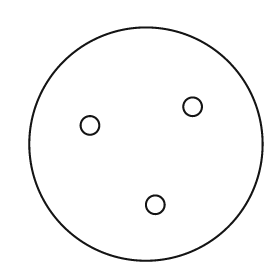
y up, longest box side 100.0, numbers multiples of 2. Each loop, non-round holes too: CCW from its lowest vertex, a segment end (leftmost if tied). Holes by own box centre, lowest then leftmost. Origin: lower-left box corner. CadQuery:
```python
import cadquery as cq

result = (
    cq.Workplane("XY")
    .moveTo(50.0, 50.0)
    .circle(50.0)
    .moveTo(54.0, 24.0)
    .circle(4.0)
    .moveTo(26.0, 58.0)
    .circle(4.0)
    .moveTo(70.0, 66.0)
    .circle(4.0)
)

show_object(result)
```